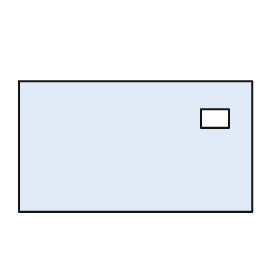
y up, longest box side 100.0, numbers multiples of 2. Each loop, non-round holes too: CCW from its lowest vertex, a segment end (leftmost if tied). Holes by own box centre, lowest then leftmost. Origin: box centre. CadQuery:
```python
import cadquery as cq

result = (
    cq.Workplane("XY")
    .moveTo(-50.0, -28.0)
    .lineTo(50.0, -28.0)
    .lineTo(50.0, 28.0)
    .lineTo(-50.0, 28.0)
    .close()
    .moveTo(28.0, 8.0)
    .lineTo(40.0, 8.0)
    .lineTo(40.0, 16.0)
    .lineTo(28.0, 16.0)
    .close()
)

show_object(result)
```